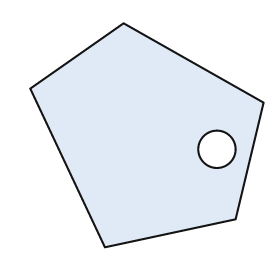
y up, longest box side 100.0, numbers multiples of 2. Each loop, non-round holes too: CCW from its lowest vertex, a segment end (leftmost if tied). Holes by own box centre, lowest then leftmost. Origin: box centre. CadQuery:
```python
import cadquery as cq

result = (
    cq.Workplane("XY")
    .moveTo(-18.0, -48.0)
    .lineTo(38.0, -36.0)
    .lineTo(50.0, 14.0)
    .lineTo(-10.0, 48.0)
    .lineTo(-50.0, 20.0)
    .close()
    .moveTo(30.0, -6.0)
    .circle(8.0)
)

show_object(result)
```